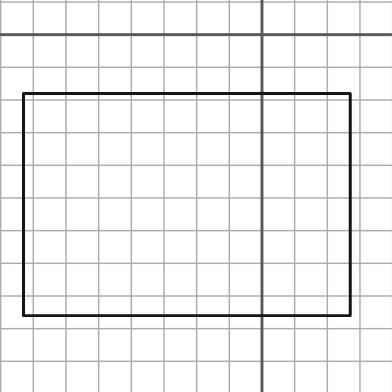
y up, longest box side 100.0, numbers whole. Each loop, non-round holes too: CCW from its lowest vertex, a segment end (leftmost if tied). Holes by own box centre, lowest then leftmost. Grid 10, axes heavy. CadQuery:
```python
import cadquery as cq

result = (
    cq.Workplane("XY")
    .moveTo(-73.0, -86.0)
    .lineTo(27.0, -86.0)
    .lineTo(27.0, -18.0)
    .lineTo(-73.0, -18.0)
    .close()
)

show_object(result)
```